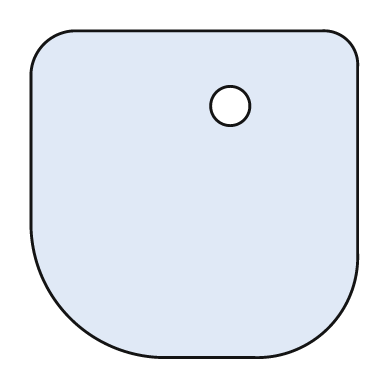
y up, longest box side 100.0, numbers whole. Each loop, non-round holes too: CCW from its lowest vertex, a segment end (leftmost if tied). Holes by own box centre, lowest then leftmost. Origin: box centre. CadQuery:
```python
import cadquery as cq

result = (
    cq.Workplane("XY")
    .moveTo(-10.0, -50.0)
    .lineTo(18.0, -50.0)
    .threePointArc((41.0, -41.0), (50.0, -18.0))
    .lineTo(50.0, 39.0)
    .threePointArc((47.0, 47.0), (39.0, 50.0))
    .lineTo(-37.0, 50.0)
    .threePointArc((-46.0, 46.0), (-50.0, 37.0))
    .lineTo(-50.0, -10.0)
    .threePointArc((-38.0, -38.0), (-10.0, -50.0))
    .close()
    .moveTo(11.0, 27.0)
    .circle(6.0)
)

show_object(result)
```